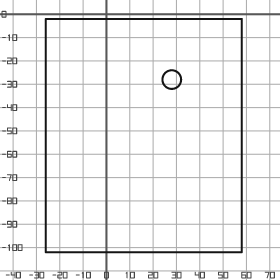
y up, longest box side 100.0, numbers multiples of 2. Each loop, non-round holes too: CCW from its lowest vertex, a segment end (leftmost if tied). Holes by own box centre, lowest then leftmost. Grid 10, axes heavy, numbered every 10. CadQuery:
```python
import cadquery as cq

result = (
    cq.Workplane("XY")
    .moveTo(-26.0, -102.0)
    .lineTo(58.0, -102.0)
    .lineTo(58.0, -2.0)
    .lineTo(-26.0, -2.0)
    .close()
    .moveTo(28.0, -28.0)
    .circle(4.0)
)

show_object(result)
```